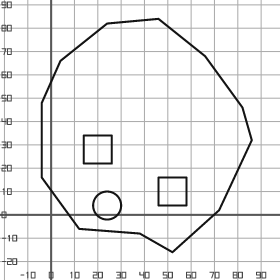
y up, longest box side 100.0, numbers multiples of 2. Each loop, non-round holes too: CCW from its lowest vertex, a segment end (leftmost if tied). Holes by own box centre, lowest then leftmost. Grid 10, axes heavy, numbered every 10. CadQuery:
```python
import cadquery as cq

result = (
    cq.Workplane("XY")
    .moveTo(52.0, -16.0)
    .lineTo(72.0, 2.0)
    .lineTo(86.0, 32.0)
    .lineTo(82.0, 46.0)
    .lineTo(66.0, 68.0)
    .lineTo(46.0, 84.0)
    .lineTo(24.0, 82.0)
    .lineTo(4.0, 66.0)
    .lineTo(-4.0, 48.0)
    .lineTo(-4.0, 16.0)
    .lineTo(12.0, -6.0)
    .lineTo(38.0, -8.0)
    .close()
    .moveTo(24.0, 4.0)
    .circle(6.0)
    .moveTo(46.0, 4.0)
    .lineTo(58.0, 4.0)
    .lineTo(58.0, 16.0)
    .lineTo(46.0, 16.0)
    .close()
    .moveTo(14.0, 22.0)
    .lineTo(26.0, 22.0)
    .lineTo(26.0, 34.0)
    .lineTo(14.0, 34.0)
    .close()
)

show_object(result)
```